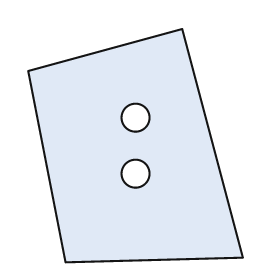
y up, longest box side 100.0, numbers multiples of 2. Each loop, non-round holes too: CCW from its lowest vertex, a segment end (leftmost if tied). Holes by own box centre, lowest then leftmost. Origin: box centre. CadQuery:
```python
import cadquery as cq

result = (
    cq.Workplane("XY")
    .moveTo(-30.0, -50.0)
    .lineTo(46.0, -48.0)
    .lineTo(20.0, 50.0)
    .lineTo(-46.0, 32.0)
    .close()
    .moveTo(0.0, -12.0)
    .circle(6.0)
    .moveTo(0.0, 12.0)
    .circle(6.0)
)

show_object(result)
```